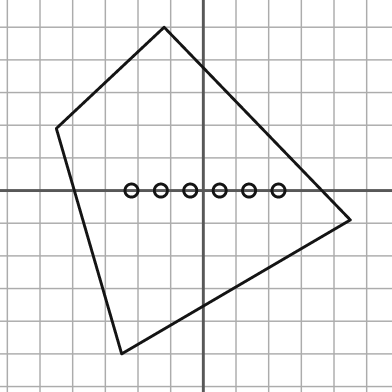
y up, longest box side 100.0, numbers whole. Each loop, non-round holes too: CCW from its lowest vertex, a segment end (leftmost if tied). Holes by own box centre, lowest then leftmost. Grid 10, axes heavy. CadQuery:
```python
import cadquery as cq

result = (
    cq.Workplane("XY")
    .moveTo(-25.0, -50.0)
    .lineTo(45.0, -9.0)
    .lineTo(-12.0, 50.0)
    .lineTo(-45.0, 19.0)
    .close()
    .moveTo(-22.0, 0.0)
    .circle(2.0)
    .moveTo(-13.0, 0.0)
    .circle(2.0)
    .moveTo(-4.0, 0.0)
    .circle(2.0)
    .moveTo(5.0, 0.0)
    .circle(2.0)
    .moveTo(14.0, 0.0)
    .circle(2.0)
    .moveTo(23.0, 0.0)
    .circle(2.0)
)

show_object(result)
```